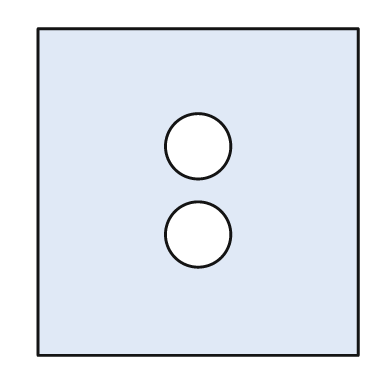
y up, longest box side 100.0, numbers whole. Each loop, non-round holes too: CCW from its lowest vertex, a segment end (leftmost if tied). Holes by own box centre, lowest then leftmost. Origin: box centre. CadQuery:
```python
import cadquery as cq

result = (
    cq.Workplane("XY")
    .moveTo(-49.0, -50.0)
    .lineTo(49.0, -50.0)
    .lineTo(49.0, 50.0)
    .lineTo(-49.0, 50.0)
    .close()
    .moveTo(0.0, -13.0)
    .circle(10.0)
    .moveTo(0.0, 14.0)
    .circle(10.0)
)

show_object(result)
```